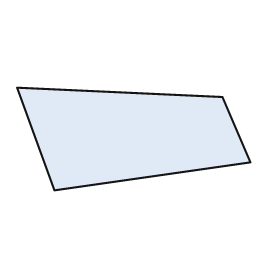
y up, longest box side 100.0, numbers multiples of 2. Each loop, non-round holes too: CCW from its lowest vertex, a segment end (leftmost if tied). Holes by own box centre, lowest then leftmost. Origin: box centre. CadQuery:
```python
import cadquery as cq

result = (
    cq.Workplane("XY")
    .moveTo(-34.0, -22.0)
    .lineTo(50.0, -10.0)
    .lineTo(38.0, 18.0)
    .lineTo(-50.0, 22.0)
    .close()
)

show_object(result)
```